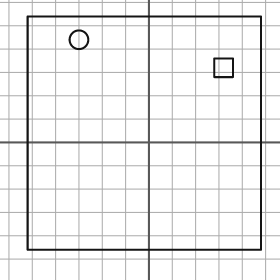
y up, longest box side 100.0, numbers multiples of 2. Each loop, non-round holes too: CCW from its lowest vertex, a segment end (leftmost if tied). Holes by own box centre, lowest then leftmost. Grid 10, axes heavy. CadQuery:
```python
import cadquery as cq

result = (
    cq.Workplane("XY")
    .moveTo(-52.0, -46.0)
    .lineTo(48.0, -46.0)
    .lineTo(48.0, 54.0)
    .lineTo(-52.0, 54.0)
    .close()
    .moveTo(28.0, 28.0)
    .lineTo(36.0, 28.0)
    .lineTo(36.0, 36.0)
    .lineTo(28.0, 36.0)
    .close()
    .moveTo(-30.0, 44.0)
    .circle(4.0)
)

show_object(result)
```